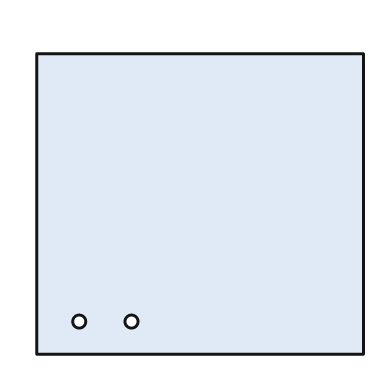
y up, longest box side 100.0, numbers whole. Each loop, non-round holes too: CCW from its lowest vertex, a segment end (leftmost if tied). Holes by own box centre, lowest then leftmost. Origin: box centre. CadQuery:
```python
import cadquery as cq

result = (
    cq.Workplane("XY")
    .moveTo(-50.0, -46.0)
    .lineTo(50.0, -46.0)
    .lineTo(50.0, 46.0)
    .lineTo(-50.0, 46.0)
    .close()
    .moveTo(-37.0, -36.0)
    .circle(2.0)
    .moveTo(-21.0, -36.0)
    .circle(2.0)
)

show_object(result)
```